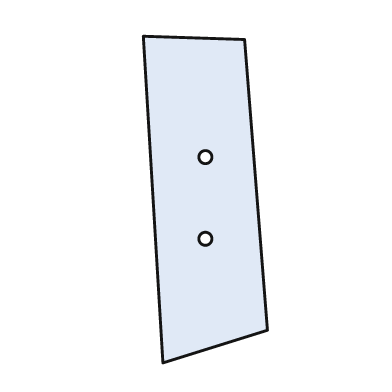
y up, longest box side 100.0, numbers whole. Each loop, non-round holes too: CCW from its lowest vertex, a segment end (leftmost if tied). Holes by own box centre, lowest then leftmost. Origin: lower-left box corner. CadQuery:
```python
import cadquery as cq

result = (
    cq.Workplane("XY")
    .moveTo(6.0, 0.0)
    .lineTo(38.0, 10.0)
    .lineTo(31.0, 99.0)
    .lineTo(0.0, 100.0)
    .close()
    .moveTo(19.0, 38.0)
    .circle(2.0)
    .moveTo(19.0, 63.0)
    .circle(2.0)
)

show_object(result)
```